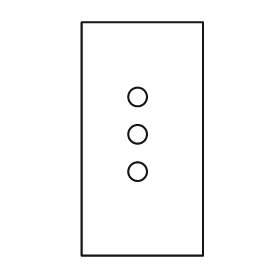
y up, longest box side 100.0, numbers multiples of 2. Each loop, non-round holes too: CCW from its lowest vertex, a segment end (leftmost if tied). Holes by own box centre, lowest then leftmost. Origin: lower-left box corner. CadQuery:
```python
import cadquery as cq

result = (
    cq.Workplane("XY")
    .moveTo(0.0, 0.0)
    .lineTo(52.0, 0.0)
    .lineTo(52.0, 100.0)
    .lineTo(0.0, 100.0)
    .close()
    .moveTo(24.0, 36.0)
    .circle(4.0)
    .moveTo(24.0, 52.0)
    .circle(4.0)
    .moveTo(24.0, 68.0)
    .circle(4.0)
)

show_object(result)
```